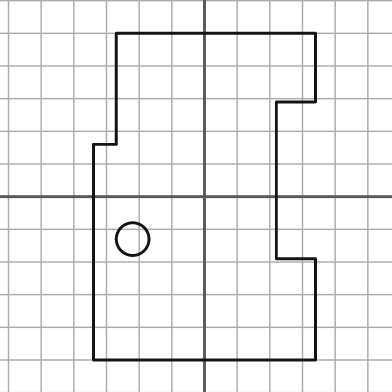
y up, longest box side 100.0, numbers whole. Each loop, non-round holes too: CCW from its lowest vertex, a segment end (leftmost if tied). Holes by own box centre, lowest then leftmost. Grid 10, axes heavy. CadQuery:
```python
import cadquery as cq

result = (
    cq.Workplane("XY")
    .moveTo(-34.0, -50.0)
    .lineTo(34.0, -50.0)
    .lineTo(34.0, -19.0)
    .lineTo(22.0, -19.0)
    .lineTo(22.0, 29.0)
    .lineTo(34.0, 29.0)
    .lineTo(34.0, 50.0)
    .lineTo(-27.0, 50.0)
    .lineTo(-27.0, 16.0)
    .lineTo(-34.0, 16.0)
    .close()
    .moveTo(-22.0, -13.0)
    .circle(5.0)
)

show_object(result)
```